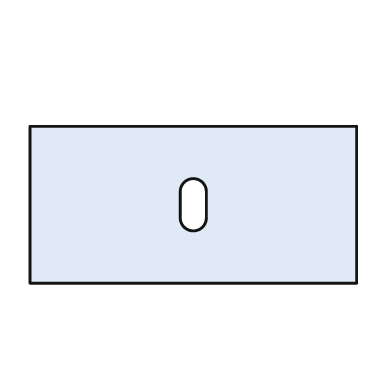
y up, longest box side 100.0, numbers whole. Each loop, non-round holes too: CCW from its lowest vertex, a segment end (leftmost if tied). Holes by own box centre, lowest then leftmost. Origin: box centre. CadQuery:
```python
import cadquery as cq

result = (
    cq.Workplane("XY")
    .moveTo(-50.0, -24.0)
    .lineTo(50.0, -24.0)
    .lineTo(50.0, 24.0)
    .lineTo(-50.0, 24.0)
    .close()
    .moveTo(-4.0, -4.0)
    .threePointArc((0.0, -8.0), (4.0, -4.0))
    .lineTo(4.0, 4.0)
    .threePointArc((0.0, 8.0), (-4.0, 4.0))
    .close()
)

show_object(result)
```